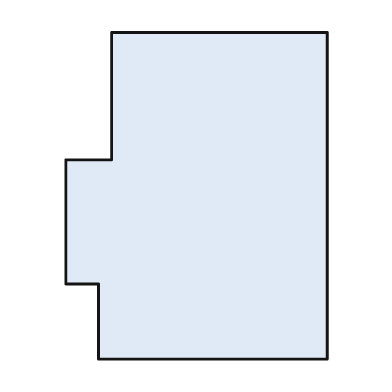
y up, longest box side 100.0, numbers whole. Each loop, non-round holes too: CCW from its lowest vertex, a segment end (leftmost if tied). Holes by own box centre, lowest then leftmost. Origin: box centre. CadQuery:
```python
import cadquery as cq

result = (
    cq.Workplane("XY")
    .moveTo(-30.0, -50.0)
    .lineTo(40.0, -50.0)
    .lineTo(40.0, 50.0)
    .lineTo(-26.0, 50.0)
    .lineTo(-26.0, 11.0)
    .lineTo(-40.0, 11.0)
    .lineTo(-40.0, -27.0)
    .lineTo(-30.0, -27.0)
    .close()
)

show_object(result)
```